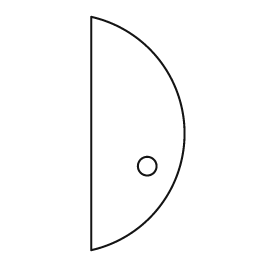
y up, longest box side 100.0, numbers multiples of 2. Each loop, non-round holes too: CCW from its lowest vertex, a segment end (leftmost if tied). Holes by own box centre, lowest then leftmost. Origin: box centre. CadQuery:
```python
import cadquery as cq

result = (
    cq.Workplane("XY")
    .moveTo(-20.0, -50.0)
    .threePointArc((20.0, 0.0), (-20.0, 50.0))
    .close()
    .moveTo(4.0, -14.0)
    .circle(4.0)
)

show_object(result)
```